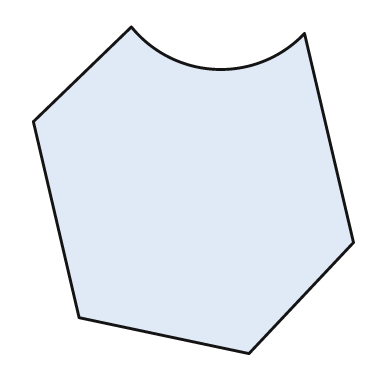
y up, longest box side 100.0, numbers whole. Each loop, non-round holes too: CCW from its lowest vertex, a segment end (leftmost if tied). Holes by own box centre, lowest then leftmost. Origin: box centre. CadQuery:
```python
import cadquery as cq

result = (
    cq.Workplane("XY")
    .moveTo(17.0, -50.0)
    .lineTo(49.0, -16.0)
    .lineTo(34.0, 48.0)
    .threePointArc((7.0, 37.0), (-19.0, 50.0))
    .lineTo(-49.0, 21.0)
    .lineTo(-35.0, -39.0)
    .close()
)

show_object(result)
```